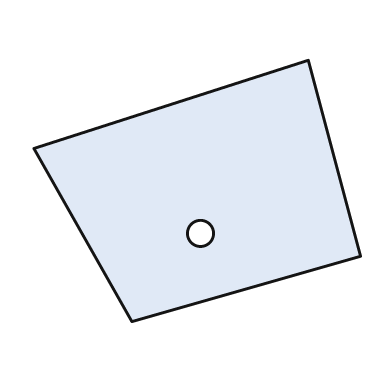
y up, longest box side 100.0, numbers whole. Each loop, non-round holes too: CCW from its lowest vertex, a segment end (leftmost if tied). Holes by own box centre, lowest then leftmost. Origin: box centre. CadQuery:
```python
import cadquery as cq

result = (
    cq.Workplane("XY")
    .moveTo(-20.0, -40.0)
    .lineTo(50.0, -20.0)
    .lineTo(34.0, 40.0)
    .lineTo(-50.0, 13.0)
    .close()
    .moveTo(1.0, -13.0)
    .circle(4.0)
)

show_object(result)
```